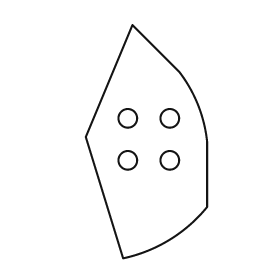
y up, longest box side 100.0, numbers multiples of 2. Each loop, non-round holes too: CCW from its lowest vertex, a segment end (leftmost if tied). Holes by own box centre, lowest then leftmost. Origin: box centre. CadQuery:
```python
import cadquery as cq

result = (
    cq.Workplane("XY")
    .moveTo(-10.0, -50.0)
    .threePointArc((10.0, -42.0), (26.0, -28.0))
    .lineTo(26.0, 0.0)
    .threePointArc((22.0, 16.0), (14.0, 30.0))
    .lineTo(-6.0, 50.0)
    .lineTo(-26.0, 2.0)
    .close()
    .moveTo(-8.0, -8.0)
    .circle(4.0)
    .moveTo(10.0, -8.0)
    .circle(4.0)
    .moveTo(-8.0, 10.0)
    .circle(4.0)
    .moveTo(10.0, 10.0)
    .circle(4.0)
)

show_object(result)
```